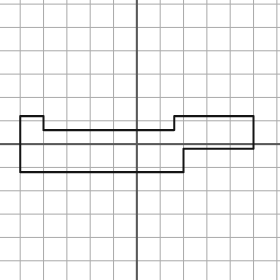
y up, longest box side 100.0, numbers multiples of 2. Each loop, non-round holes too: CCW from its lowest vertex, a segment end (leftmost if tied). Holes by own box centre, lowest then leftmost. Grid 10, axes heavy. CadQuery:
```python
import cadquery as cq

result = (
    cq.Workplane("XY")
    .moveTo(-50.0, -12.0)
    .lineTo(20.0, -12.0)
    .lineTo(20.0, -2.0)
    .lineTo(50.0, -2.0)
    .lineTo(50.0, 12.0)
    .lineTo(16.0, 12.0)
    .lineTo(16.0, 6.0)
    .lineTo(-40.0, 6.0)
    .lineTo(-40.0, 12.0)
    .lineTo(-50.0, 12.0)
    .close()
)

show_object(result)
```